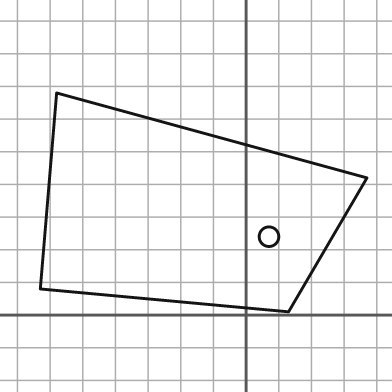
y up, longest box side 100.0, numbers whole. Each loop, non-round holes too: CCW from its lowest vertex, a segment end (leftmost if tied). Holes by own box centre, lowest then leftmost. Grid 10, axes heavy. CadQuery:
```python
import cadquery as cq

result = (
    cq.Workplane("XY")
    .moveTo(13.0, 1.0)
    .lineTo(37.0, 42.0)
    .lineTo(-58.0, 68.0)
    .lineTo(-63.0, 8.0)
    .close()
    .moveTo(7.0, 24.0)
    .circle(3.0)
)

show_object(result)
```